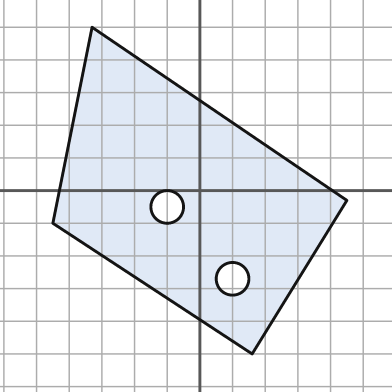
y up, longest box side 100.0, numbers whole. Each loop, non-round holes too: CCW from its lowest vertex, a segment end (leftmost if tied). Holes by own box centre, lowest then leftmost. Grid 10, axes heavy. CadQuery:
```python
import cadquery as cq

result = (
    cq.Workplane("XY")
    .moveTo(16.0, -50.0)
    .lineTo(45.0, -3.0)
    .lineTo(-33.0, 50.0)
    .lineTo(-45.0, -10.0)
    .close()
    .moveTo(10.0, -27.0)
    .circle(5.0)
    .moveTo(-10.0, -5.0)
    .circle(5.0)
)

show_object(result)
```